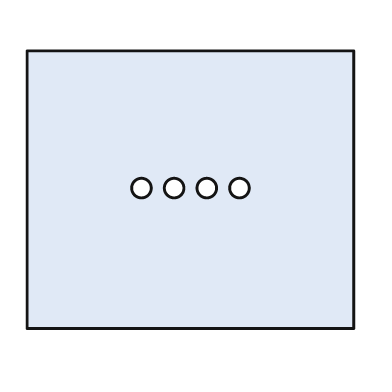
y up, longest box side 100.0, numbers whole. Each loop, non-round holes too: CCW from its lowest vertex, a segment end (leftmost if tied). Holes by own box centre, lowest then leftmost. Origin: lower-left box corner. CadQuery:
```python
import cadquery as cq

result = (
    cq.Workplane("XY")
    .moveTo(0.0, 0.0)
    .lineTo(100.0, 0.0)
    .lineTo(100.0, 85.0)
    .lineTo(0.0, 85.0)
    .close()
    .moveTo(35.0, 43.0)
    .circle(3.0)
    .moveTo(45.0, 43.0)
    .circle(3.0)
    .moveTo(55.0, 43.0)
    .circle(3.0)
    .moveTo(65.0, 43.0)
    .circle(3.0)
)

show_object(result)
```